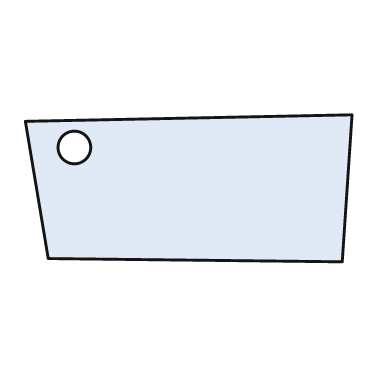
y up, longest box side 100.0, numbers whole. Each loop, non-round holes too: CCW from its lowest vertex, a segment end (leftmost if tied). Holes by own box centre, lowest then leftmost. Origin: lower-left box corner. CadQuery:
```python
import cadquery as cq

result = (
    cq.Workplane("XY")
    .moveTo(97.0, 0.0)
    .lineTo(100.0, 45.0)
    .lineTo(0.0, 43.0)
    .lineTo(7.0, 1.0)
    .close()
    .moveTo(15.0, 35.0)
    .circle(5.0)
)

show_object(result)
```